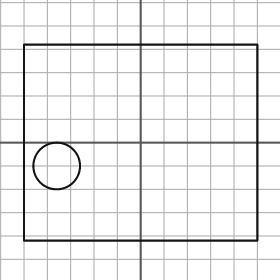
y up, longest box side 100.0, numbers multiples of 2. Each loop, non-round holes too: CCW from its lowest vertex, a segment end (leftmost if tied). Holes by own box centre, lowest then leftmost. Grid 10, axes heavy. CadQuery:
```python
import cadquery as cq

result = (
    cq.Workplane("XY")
    .moveTo(-50.0, -42.0)
    .lineTo(50.0, -42.0)
    .lineTo(50.0, 42.0)
    .lineTo(-50.0, 42.0)
    .close()
    .moveTo(-36.0, -10.0)
    .circle(10.0)
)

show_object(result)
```